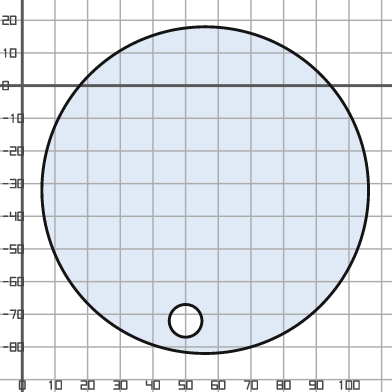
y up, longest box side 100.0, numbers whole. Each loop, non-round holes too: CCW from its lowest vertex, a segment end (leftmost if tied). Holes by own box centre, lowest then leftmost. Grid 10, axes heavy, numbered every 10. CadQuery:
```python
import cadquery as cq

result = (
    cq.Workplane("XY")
    .moveTo(56.0, -32.0)
    .circle(50.0)
    .moveTo(50.0, -72.0)
    .circle(5.0)
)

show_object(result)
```